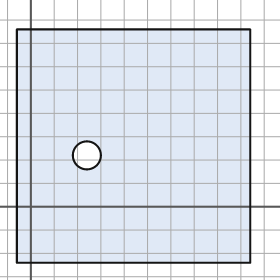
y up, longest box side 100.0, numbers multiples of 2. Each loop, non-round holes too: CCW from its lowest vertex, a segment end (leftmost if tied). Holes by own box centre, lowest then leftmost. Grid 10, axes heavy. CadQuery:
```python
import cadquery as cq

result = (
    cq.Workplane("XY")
    .moveTo(-6.0, -24.0)
    .lineTo(94.0, -24.0)
    .lineTo(94.0, 76.0)
    .lineTo(-6.0, 76.0)
    .close()
    .moveTo(24.0, 22.0)
    .circle(6.0)
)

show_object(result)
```